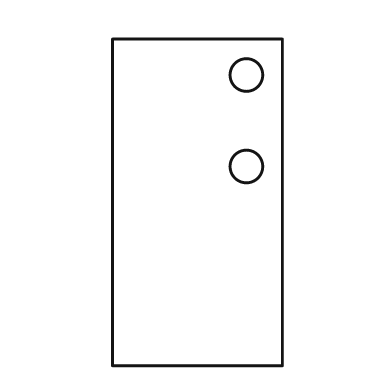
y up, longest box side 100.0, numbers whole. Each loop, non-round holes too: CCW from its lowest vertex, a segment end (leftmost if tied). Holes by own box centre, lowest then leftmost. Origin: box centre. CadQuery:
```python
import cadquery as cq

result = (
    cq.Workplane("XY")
    .moveTo(-26.0, -50.0)
    .lineTo(26.0, -50.0)
    .lineTo(26.0, 50.0)
    .lineTo(-26.0, 50.0)
    .close()
    .moveTo(15.0, 11.0)
    .circle(5.0)
    .moveTo(15.0, 39.0)
    .circle(5.0)
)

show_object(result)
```